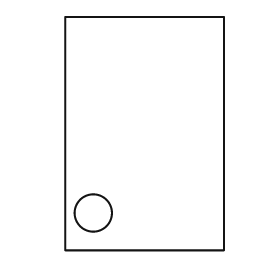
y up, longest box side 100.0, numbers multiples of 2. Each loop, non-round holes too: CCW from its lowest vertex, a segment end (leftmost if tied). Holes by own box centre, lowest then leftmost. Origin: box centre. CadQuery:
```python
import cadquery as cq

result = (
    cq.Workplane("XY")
    .moveTo(-34.0, -50.0)
    .lineTo(34.0, -50.0)
    .lineTo(34.0, 50.0)
    .lineTo(-34.0, 50.0)
    .close()
    .moveTo(-22.0, -34.0)
    .circle(8.0)
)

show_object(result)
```